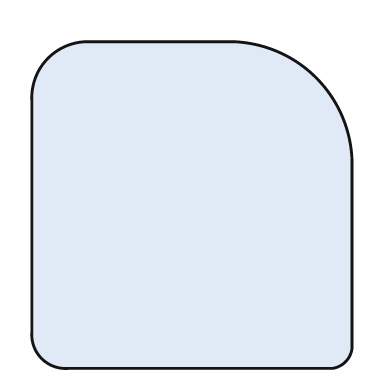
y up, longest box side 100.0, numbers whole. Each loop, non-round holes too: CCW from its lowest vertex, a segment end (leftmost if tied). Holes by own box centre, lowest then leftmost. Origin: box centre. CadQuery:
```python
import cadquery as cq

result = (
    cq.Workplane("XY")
    .moveTo(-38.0, -50.0)
    .lineTo(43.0, -50.0)
    .threePointArc((47.0, -48.0), (49.0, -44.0))
    .lineTo(49.0, 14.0)
    .threePointArc((38.0, 39.0), (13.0, 50.0))
    .lineTo(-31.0, 50.0)
    .threePointArc((-44.0, 45.0), (-49.0, 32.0))
    .lineTo(-49.0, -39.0)
    .threePointArc((-46.0, -47.0), (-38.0, -50.0))
    .close()
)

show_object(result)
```